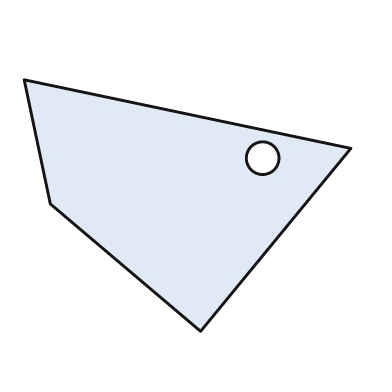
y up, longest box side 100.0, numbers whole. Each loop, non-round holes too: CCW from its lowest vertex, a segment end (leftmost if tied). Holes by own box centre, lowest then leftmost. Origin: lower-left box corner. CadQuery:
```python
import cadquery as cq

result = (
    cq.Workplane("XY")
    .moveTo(54.0, 0.0)
    .lineTo(100.0, 56.0)
    .lineTo(0.0, 77.0)
    .lineTo(8.0, 39.0)
    .close()
    .moveTo(73.0, 53.0)
    .circle(5.0)
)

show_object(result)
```